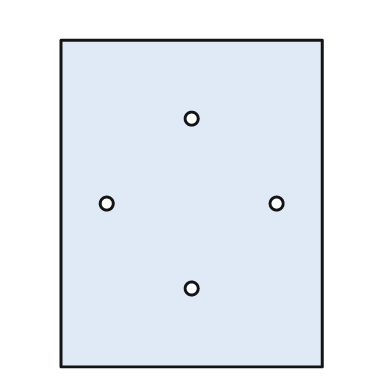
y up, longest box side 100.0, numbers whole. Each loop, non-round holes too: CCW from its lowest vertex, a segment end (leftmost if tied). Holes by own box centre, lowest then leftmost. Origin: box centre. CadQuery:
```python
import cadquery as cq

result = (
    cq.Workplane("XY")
    .moveTo(-40.0, -50.0)
    .lineTo(40.0, -50.0)
    .lineTo(40.0, 50.0)
    .lineTo(-40.0, 50.0)
    .close()
    .moveTo(0.0, -26.0)
    .circle(2.0)
    .moveTo(-26.0, 0.0)
    .circle(2.0)
    .moveTo(26.0, 0.0)
    .circle(2.0)
    .moveTo(0.0, 26.0)
    .circle(2.0)
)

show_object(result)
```